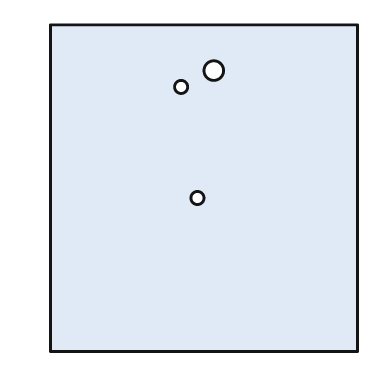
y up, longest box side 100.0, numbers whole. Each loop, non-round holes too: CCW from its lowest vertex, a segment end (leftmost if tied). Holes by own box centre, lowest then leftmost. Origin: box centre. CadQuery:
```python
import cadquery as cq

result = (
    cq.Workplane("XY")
    .moveTo(-47.0, -50.0)
    .lineTo(47.0, -50.0)
    .lineTo(47.0, 50.0)
    .lineTo(-47.0, 50.0)
    .close()
    .moveTo(-2.0, -3.0)
    .circle(2.0)
    .moveTo(-7.0, 31.0)
    .circle(2.0)
    .moveTo(3.0, 36.0)
    .circle(3.0)
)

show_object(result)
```